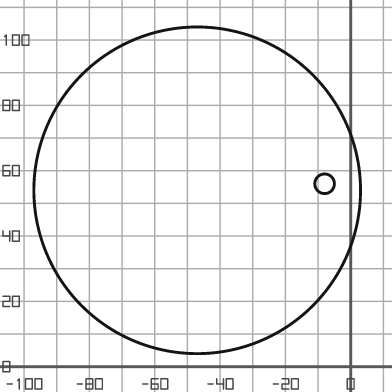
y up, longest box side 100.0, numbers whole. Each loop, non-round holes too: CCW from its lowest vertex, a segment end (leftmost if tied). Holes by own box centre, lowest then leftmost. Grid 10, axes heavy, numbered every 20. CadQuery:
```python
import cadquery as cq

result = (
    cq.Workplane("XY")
    .moveTo(-47.0, 54.0)
    .circle(50.0)
    .moveTo(-8.0, 56.0)
    .circle(3.0)
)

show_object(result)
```